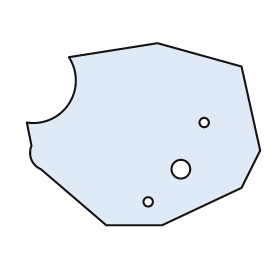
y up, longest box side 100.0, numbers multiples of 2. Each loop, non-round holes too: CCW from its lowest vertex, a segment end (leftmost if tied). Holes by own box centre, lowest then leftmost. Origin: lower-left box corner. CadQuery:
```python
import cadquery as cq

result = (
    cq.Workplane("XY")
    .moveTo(34.0, 0.0)
    .lineTo(58.0, 0.0)
    .lineTo(92.0, 16.0)
    .lineTo(100.0, 32.0)
    .lineTo(92.0, 68.0)
    .lineTo(56.0, 78.0)
    .lineTo(18.0, 72.0)
    .threePointArc((18.0, 52.0), (0.0, 44.0))
    .lineTo(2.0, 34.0)
    .threePointArc((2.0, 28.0), (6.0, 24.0))
    .close()
    .moveTo(52.0, 10.0)
    .circle(2.0)
    .moveTo(66.0, 24.0)
    .circle(4.0)
    .moveTo(76.0, 44.0)
    .circle(2.0)
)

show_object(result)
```